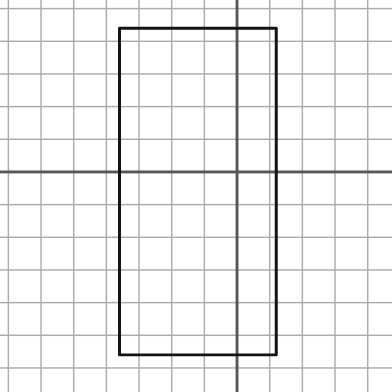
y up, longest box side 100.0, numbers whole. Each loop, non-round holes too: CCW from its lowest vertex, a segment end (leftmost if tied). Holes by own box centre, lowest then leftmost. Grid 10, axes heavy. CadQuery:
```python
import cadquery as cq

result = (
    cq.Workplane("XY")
    .moveTo(-36.0, -56.0)
    .lineTo(12.0, -56.0)
    .lineTo(12.0, 44.0)
    .lineTo(-36.0, 44.0)
    .close()
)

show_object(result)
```